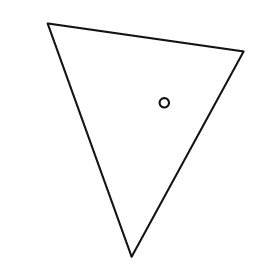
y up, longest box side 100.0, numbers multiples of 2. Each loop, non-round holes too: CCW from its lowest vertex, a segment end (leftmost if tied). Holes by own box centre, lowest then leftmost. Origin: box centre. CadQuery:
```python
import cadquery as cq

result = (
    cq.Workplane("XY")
    .moveTo(-6.0, -50.0)
    .lineTo(42.0, 38.0)
    .lineTo(-42.0, 50.0)
    .close()
    .moveTo(8.0, 16.0)
    .circle(2.0)
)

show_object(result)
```